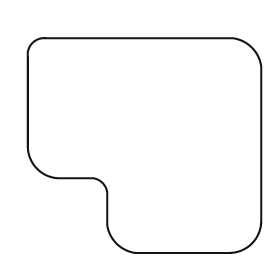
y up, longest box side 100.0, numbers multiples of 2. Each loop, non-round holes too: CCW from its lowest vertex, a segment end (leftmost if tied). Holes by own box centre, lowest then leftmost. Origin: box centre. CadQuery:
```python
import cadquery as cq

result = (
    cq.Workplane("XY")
    .moveTo(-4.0, -46.0)
    .lineTo(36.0, -46.0)
    .threePointArc((46.0, -42.0), (50.0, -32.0))
    .lineTo(50.0, 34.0)
    .threePointArc((46.0, 42.0), (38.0, 46.0))
    .lineTo(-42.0, 46.0)
    .threePointArc((-48.0, 44.0), (-50.0, 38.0))
    .lineTo(-50.0, 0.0)
    .threePointArc((-46.0, -10.0), (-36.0, -14.0))
    .lineTo(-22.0, -14.0)
    .threePointArc((-18.0, -16.0), (-16.0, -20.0))
    .lineTo(-16.0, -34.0)
    .threePointArc((-12.0, -42.0), (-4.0, -46.0))
    .close()
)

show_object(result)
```